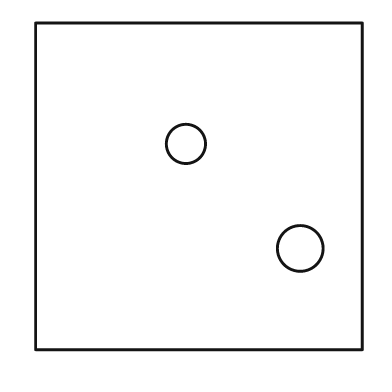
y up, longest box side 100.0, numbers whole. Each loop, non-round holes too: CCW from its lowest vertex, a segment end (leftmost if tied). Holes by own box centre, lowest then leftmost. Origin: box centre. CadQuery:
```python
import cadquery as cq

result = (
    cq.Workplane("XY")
    .moveTo(-50.0, -50.0)
    .lineTo(50.0, -50.0)
    .lineTo(50.0, 50.0)
    .lineTo(-50.0, 50.0)
    .close()
    .moveTo(31.0, -19.0)
    .circle(7.0)
    .moveTo(-4.0, 13.0)
    .circle(6.0)
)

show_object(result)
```